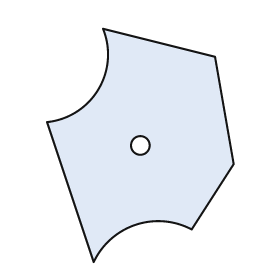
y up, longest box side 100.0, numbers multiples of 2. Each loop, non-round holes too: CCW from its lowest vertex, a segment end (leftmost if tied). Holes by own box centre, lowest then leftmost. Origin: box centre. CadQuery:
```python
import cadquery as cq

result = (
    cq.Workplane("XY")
    .moveTo(-20.0, -50.0)
    .threePointArc((-2.0, -34.0), (22.0, -36.0))
    .lineTo(40.0, -8.0)
    .lineTo(32.0, 38.0)
    .lineTo(-16.0, 50.0)
    .threePointArc((-18.0, 24.0), (-40.0, 10.0))
    .close()
    .moveTo(0.0, 0.0)
    .circle(4.0)
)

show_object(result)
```